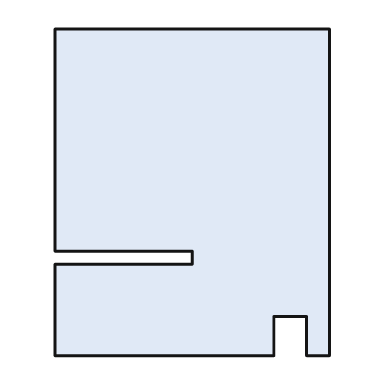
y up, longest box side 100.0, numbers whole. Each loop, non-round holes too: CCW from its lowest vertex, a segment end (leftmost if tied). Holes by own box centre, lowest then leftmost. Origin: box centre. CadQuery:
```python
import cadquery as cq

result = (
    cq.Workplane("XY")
    .moveTo(-42.0, -50.0)
    .lineTo(25.0, -50.0)
    .lineTo(25.0, -38.0)
    .lineTo(35.0, -38.0)
    .lineTo(35.0, -50.0)
    .lineTo(42.0, -50.0)
    .lineTo(42.0, 50.0)
    .lineTo(-42.0, 50.0)
    .lineTo(-42.0, -18.0)
    .lineTo(0.0, -18.0)
    .lineTo(0.0, -22.0)
    .lineTo(-42.0, -22.0)
    .close()
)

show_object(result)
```